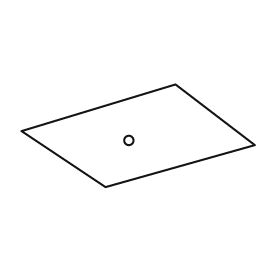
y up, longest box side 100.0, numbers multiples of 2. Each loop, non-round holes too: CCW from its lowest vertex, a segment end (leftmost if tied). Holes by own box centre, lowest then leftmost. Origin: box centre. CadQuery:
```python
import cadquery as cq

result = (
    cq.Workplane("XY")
    .moveTo(-14.0, -22.0)
    .lineTo(50.0, -4.0)
    .lineTo(16.0, 22.0)
    .lineTo(-50.0, 2.0)
    .close()
    .moveTo(-4.0, -2.0)
    .circle(2.0)
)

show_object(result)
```